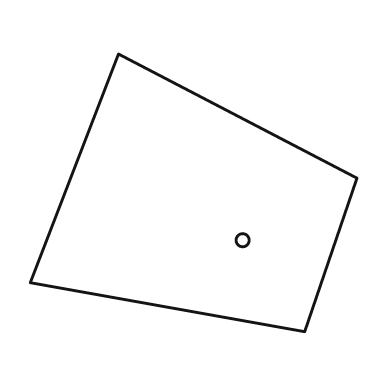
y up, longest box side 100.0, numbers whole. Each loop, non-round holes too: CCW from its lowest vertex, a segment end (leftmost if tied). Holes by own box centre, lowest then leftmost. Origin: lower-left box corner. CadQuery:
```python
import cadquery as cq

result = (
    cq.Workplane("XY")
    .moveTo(84.0, 0.0)
    .lineTo(100.0, 47.0)
    .lineTo(27.0, 85.0)
    .lineTo(0.0, 15.0)
    .close()
    .moveTo(65.0, 28.0)
    .circle(2.0)
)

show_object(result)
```